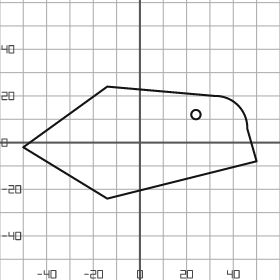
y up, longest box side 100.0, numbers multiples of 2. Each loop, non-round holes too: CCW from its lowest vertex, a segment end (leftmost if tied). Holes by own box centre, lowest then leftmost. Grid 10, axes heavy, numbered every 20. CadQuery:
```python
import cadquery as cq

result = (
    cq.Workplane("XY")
    .moveTo(-14.0, -24.0)
    .lineTo(50.0, -8.0)
    .lineTo(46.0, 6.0)
    .threePointArc((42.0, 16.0), (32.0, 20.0))
    .lineTo(-14.0, 24.0)
    .lineTo(-50.0, -2.0)
    .close()
    .moveTo(24.0, 12.0)
    .circle(2.0)
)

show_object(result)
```